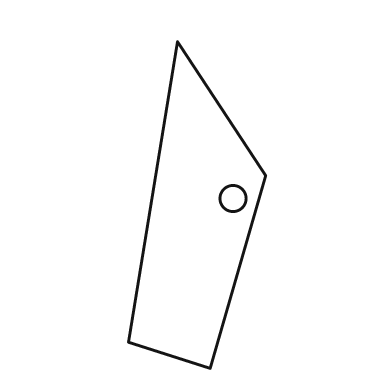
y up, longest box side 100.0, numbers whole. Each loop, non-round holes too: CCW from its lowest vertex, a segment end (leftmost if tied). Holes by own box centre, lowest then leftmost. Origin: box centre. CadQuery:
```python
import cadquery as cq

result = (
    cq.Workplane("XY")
    .moveTo(4.0, -50.0)
    .lineTo(21.0, 9.0)
    .lineTo(-6.0, 50.0)
    .lineTo(-21.0, -42.0)
    .close()
    .moveTo(11.0, 2.0)
    .circle(4.0)
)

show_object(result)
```